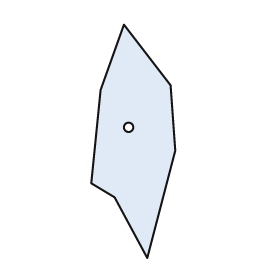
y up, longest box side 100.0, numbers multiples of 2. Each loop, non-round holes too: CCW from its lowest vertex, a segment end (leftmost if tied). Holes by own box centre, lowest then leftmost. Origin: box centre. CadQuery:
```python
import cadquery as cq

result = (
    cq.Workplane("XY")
    .moveTo(6.0, -50.0)
    .lineTo(18.0, -4.0)
    .lineTo(16.0, 24.0)
    .lineTo(-4.0, 50.0)
    .lineTo(-14.0, 22.0)
    .lineTo(-18.0, -18.0)
    .lineTo(-8.0, -24.0)
    .close()
    .moveTo(-2.0, 6.0)
    .circle(2.0)
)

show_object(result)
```